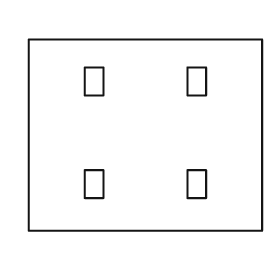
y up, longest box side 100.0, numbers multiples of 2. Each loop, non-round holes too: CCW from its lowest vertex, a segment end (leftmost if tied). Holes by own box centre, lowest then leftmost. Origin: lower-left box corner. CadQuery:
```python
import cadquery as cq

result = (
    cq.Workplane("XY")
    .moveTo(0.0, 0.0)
    .lineTo(100.0, 0.0)
    .lineTo(100.0, 82.0)
    .lineTo(0.0, 82.0)
    .close()
    .moveTo(24.0, 14.0)
    .lineTo(32.0, 14.0)
    .lineTo(32.0, 26.0)
    .lineTo(24.0, 26.0)
    .close()
    .moveTo(68.0, 14.0)
    .lineTo(76.0, 14.0)
    .lineTo(76.0, 26.0)
    .lineTo(68.0, 26.0)
    .close()
    .moveTo(24.0, 58.0)
    .lineTo(32.0, 58.0)
    .lineTo(32.0, 70.0)
    .lineTo(24.0, 70.0)
    .close()
    .moveTo(68.0, 58.0)
    .lineTo(76.0, 58.0)
    .lineTo(76.0, 70.0)
    .lineTo(68.0, 70.0)
    .close()
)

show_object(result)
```